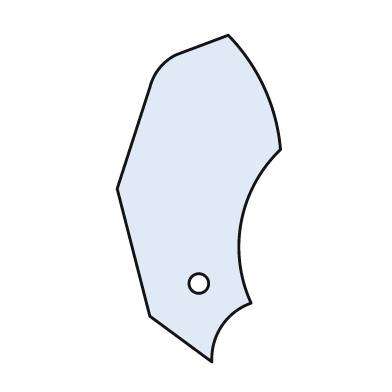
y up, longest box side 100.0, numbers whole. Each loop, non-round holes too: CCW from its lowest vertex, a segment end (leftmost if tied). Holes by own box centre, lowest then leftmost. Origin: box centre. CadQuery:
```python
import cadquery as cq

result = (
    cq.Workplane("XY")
    .moveTo(4.0, -50.0)
    .threePointArc((7.0, -39.0), (16.0, -32.0))
    .threePointArc((13.0, -7.0), (25.0, 15.0))
    .threePointArc((20.0, 34.0), (9.0, 50.0))
    .lineTo(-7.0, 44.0)
    .threePointArc((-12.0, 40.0), (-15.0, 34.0))
    .lineTo(-25.0, 3.0)
    .lineTo(-15.0, -36.0)
    .close()
    .moveTo(0.0, -26.0)
    .circle(3.0)
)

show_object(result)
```